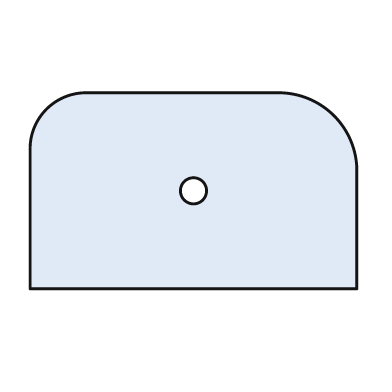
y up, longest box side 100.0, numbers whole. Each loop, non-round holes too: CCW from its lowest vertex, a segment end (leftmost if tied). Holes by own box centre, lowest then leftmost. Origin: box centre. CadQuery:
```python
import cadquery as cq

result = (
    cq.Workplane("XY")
    .moveTo(-50.0, -30.0)
    .lineTo(50.0, -30.0)
    .lineTo(50.0, 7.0)
    .threePointArc((43.0, 23.0), (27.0, 30.0))
    .lineTo(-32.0, 30.0)
    .threePointArc((-45.0, 25.0), (-50.0, 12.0))
    .close()
    .moveTo(0.0, 0.0)
    .circle(4.0)
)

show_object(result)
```